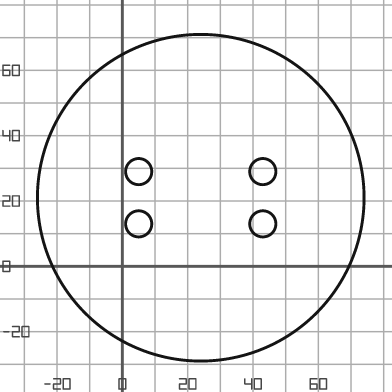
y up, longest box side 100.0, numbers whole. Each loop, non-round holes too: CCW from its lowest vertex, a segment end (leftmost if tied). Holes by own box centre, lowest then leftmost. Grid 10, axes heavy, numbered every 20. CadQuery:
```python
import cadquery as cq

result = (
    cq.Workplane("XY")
    .moveTo(24.0, 21.0)
    .circle(50.0)
    .moveTo(5.0, 13.0)
    .circle(4.0)
    .moveTo(43.0, 13.0)
    .circle(4.0)
    .moveTo(5.0, 29.0)
    .circle(4.0)
    .moveTo(43.0, 29.0)
    .circle(4.0)
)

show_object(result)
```